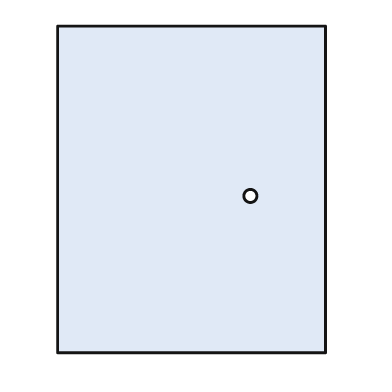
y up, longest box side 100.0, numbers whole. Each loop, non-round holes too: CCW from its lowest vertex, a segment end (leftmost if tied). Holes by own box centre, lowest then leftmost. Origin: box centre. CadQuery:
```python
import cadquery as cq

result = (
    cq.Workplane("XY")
    .moveTo(-41.0, -50.0)
    .lineTo(41.0, -50.0)
    .lineTo(41.0, 50.0)
    .lineTo(-41.0, 50.0)
    .close()
    .moveTo(18.0, -2.0)
    .circle(2.0)
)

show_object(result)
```